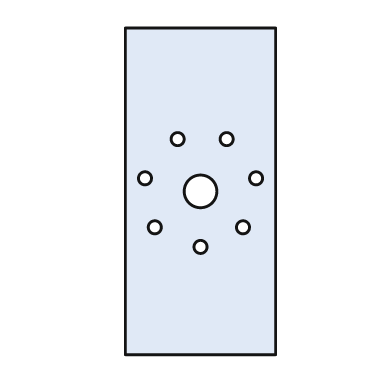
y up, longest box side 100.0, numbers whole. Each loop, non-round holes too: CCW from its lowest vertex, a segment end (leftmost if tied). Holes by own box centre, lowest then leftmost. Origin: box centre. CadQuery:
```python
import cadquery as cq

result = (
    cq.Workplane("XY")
    .moveTo(-23.0, -50.0)
    .lineTo(23.0, -50.0)
    .lineTo(23.0, 50.0)
    .lineTo(-23.0, 50.0)
    .close()
    .moveTo(0.0, -17.0)
    .circle(2.0)
    .moveTo(-14.0, -11.0)
    .circle(2.0)
    .moveTo(13.0, -11.0)
    .circle(2.0)
    .moveTo(0.0, 0.0)
    .circle(5.0)
    .moveTo(-17.0, 4.0)
    .circle(2.0)
    .moveTo(17.0, 4.0)
    .circle(2.0)
    .moveTo(-7.0, 16.0)
    .circle(2.0)
    .moveTo(8.0, 16.0)
    .circle(2.0)
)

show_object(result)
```